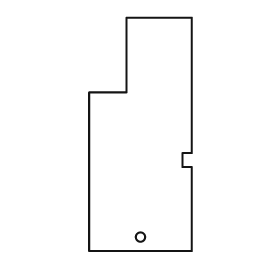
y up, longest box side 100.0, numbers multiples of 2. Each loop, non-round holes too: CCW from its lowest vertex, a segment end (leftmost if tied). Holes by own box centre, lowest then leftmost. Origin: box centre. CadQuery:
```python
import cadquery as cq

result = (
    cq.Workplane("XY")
    .moveTo(-22.0, -50.0)
    .lineTo(22.0, -50.0)
    .lineTo(22.0, -14.0)
    .lineTo(18.0, -14.0)
    .lineTo(18.0, -8.0)
    .lineTo(22.0, -8.0)
    .lineTo(22.0, 50.0)
    .lineTo(-6.0, 50.0)
    .lineTo(-6.0, 18.0)
    .lineTo(-22.0, 18.0)
    .close()
    .moveTo(0.0, -44.0)
    .circle(2.0)
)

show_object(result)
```